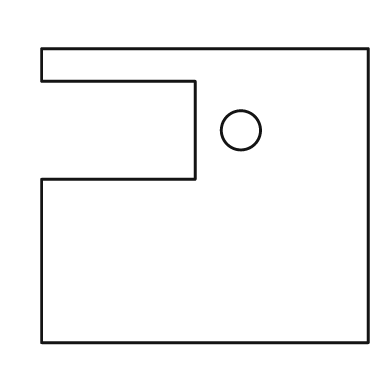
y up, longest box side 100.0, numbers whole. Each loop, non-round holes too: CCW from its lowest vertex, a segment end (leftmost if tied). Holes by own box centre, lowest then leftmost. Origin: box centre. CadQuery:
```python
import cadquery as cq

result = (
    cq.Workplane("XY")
    .moveTo(-50.0, -45.0)
    .lineTo(50.0, -45.0)
    .lineTo(50.0, 45.0)
    .lineTo(-50.0, 45.0)
    .lineTo(-50.0, 35.0)
    .lineTo(-3.0, 35.0)
    .lineTo(-3.0, 5.0)
    .lineTo(-50.0, 5.0)
    .close()
    .moveTo(11.0, 20.0)
    .circle(6.0)
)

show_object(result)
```